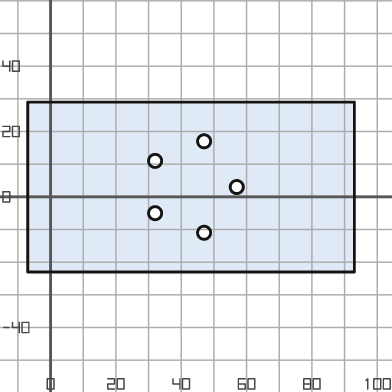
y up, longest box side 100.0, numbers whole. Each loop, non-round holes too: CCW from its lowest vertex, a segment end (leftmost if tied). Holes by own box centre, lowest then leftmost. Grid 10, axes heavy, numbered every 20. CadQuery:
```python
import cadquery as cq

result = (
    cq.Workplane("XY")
    .moveTo(-7.0, -23.0)
    .lineTo(93.0, -23.0)
    .lineTo(93.0, 29.0)
    .lineTo(-7.0, 29.0)
    .close()
    .moveTo(47.0, -11.0)
    .circle(2.0)
    .moveTo(32.0, -5.0)
    .circle(2.0)
    .moveTo(57.0, 3.0)
    .circle(2.0)
    .moveTo(32.0, 11.0)
    .circle(2.0)
    .moveTo(47.0, 17.0)
    .circle(2.0)
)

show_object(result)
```